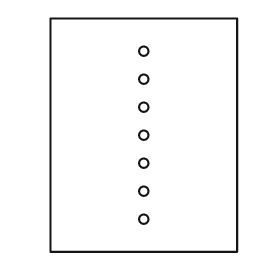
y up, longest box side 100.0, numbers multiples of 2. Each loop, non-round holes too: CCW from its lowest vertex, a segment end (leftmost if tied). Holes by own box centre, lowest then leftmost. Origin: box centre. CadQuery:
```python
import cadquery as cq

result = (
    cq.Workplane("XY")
    .moveTo(-40.0, -50.0)
    .lineTo(40.0, -50.0)
    .lineTo(40.0, 50.0)
    .lineTo(-40.0, 50.0)
    .close()
    .moveTo(0.0, -36.0)
    .circle(2.0)
    .moveTo(0.0, -24.0)
    .circle(2.0)
    .moveTo(0.0, -12.0)
    .circle(2.0)
    .moveTo(0.0, 0.0)
    .circle(2.0)
    .moveTo(0.0, 12.0)
    .circle(2.0)
    .moveTo(0.0, 24.0)
    .circle(2.0)
    .moveTo(0.0, 36.0)
    .circle(2.0)
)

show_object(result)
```